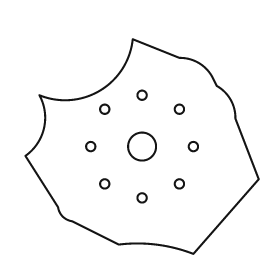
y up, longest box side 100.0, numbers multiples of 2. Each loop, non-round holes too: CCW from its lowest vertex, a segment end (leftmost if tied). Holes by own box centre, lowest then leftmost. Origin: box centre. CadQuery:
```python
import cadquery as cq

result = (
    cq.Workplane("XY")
    .moveTo(22.0, -46.0)
    .lineTo(50.0, -14.0)
    .lineTo(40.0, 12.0)
    .threePointArc((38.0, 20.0), (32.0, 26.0))
    .lineTo(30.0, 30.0)
    .threePointArc((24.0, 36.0), (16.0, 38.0))
    .lineTo(-4.0, 46.0)
    .threePointArc((-18.0, 24.0), (-44.0, 22.0))
    .threePointArc((-42.0, 8.0), (-50.0, -4.0))
    .lineTo(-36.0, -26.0)
    .threePointArc((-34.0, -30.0), (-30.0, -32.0))
    .lineTo(-10.0, -42.0)
    .threePointArc((6.0, -42.0), (22.0, -46.0))
    .close()
    .moveTo(0.0, -22.0)
    .circle(2.0)
    .moveTo(-16.0, -16.0)
    .circle(2.0)
    .moveTo(16.0, -16.0)
    .circle(2.0)
    .moveTo(-22.0, 0.0)
    .circle(2.0)
    .moveTo(0.0, 0.0)
    .circle(6.0)
    .moveTo(22.0, 0.0)
    .circle(2.0)
    .moveTo(-16.0, 16.0)
    .circle(2.0)
    .moveTo(16.0, 16.0)
    .circle(2.0)
    .moveTo(0.0, 22.0)
    .circle(2.0)
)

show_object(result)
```